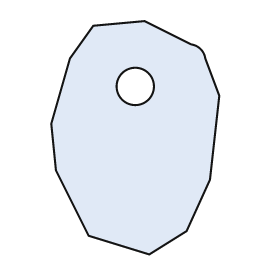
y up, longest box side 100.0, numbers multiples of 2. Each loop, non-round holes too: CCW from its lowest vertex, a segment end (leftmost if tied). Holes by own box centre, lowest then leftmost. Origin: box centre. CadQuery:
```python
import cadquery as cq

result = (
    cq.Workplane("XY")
    .moveTo(6.0, -50.0)
    .lineTo(22.0, -40.0)
    .lineTo(32.0, -18.0)
    .lineTo(36.0, 18.0)
    .lineTo(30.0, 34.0)
    .threePointArc((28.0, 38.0), (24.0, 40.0))
    .lineTo(4.0, 50.0)
    .lineTo(-18.0, 48.0)
    .lineTo(-28.0, 34.0)
    .lineTo(-36.0, 6.0)
    .lineTo(-34.0, -14.0)
    .lineTo(-20.0, -42.0)
    .close()
    .moveTo(0.0, 22.0)
    .circle(8.0)
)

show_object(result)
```